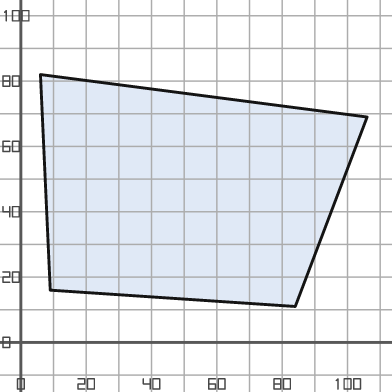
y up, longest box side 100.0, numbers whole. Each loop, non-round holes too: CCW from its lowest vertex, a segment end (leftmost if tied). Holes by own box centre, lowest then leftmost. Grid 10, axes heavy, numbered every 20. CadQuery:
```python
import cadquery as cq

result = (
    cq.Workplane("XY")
    .moveTo(84.0, 11.0)
    .lineTo(106.0, 69.0)
    .lineTo(6.0, 82.0)
    .lineTo(9.0, 16.0)
    .close()
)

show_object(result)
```